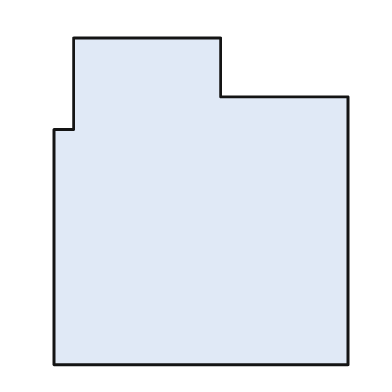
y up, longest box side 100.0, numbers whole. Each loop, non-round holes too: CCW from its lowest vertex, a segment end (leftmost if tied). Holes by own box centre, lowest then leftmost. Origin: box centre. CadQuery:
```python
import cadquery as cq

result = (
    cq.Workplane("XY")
    .moveTo(-45.0, -50.0)
    .lineTo(45.0, -50.0)
    .lineTo(45.0, 32.0)
    .lineTo(6.0, 32.0)
    .lineTo(6.0, 50.0)
    .lineTo(-39.0, 50.0)
    .lineTo(-39.0, 22.0)
    .lineTo(-45.0, 22.0)
    .close()
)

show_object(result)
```